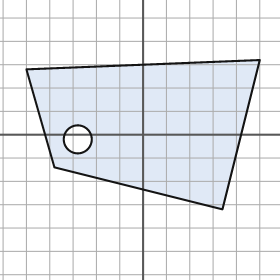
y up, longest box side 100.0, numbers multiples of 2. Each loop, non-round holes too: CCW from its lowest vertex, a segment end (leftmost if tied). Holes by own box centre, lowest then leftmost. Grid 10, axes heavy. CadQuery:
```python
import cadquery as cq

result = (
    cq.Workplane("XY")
    .moveTo(34.0, -32.0)
    .lineTo(50.0, 32.0)
    .lineTo(-50.0, 28.0)
    .lineTo(-38.0, -14.0)
    .close()
    .moveTo(-28.0, -2.0)
    .circle(6.0)
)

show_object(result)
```